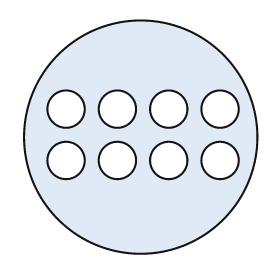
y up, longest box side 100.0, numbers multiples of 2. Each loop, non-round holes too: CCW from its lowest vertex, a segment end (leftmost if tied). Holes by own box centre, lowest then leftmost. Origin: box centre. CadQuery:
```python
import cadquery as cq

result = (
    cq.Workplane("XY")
    .moveTo(0.0, 0.0)
    .circle(50.0)
    .moveTo(-32.0, -10.0)
    .circle(8.0)
    .moveTo(-10.0, -10.0)
    .circle(8.0)
    .moveTo(12.0, -10.0)
    .circle(8.0)
    .moveTo(34.0, -10.0)
    .circle(8.0)
    .moveTo(-32.0, 12.0)
    .circle(8.0)
    .moveTo(-10.0, 12.0)
    .circle(8.0)
    .moveTo(12.0, 12.0)
    .circle(8.0)
    .moveTo(34.0, 12.0)
    .circle(8.0)
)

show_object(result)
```